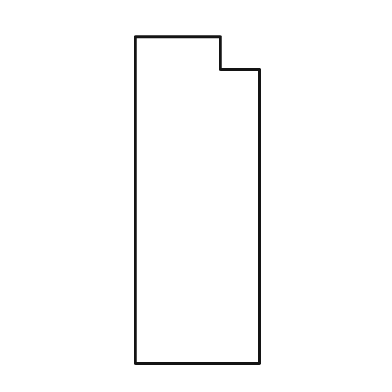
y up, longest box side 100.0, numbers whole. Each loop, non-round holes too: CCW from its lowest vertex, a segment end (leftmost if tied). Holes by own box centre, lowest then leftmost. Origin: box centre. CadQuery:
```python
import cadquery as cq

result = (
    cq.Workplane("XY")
    .moveTo(-19.0, -50.0)
    .lineTo(19.0, -50.0)
    .lineTo(19.0, 40.0)
    .lineTo(7.0, 40.0)
    .lineTo(7.0, 50.0)
    .lineTo(-19.0, 50.0)
    .close()
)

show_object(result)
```